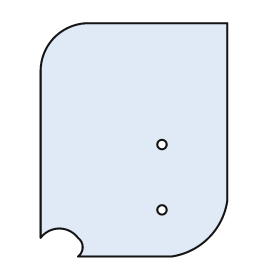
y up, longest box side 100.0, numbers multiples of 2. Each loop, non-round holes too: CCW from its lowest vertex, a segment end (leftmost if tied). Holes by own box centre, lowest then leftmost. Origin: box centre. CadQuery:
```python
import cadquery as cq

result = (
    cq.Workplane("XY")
    .moveTo(-24.0, -50.0)
    .lineTo(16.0, -50.0)
    .threePointArc((32.0, -42.0), (40.0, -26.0))
    .lineTo(40.0, 50.0)
    .lineTo(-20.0, 50.0)
    .threePointArc((-34.0, 44.0), (-40.0, 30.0))
    .lineTo(-40.0, -42.0)
    .threePointArc((-32.0, -38.0), (-24.0, -42.0))
    .threePointArc((-22.0, -46.0), (-24.0, -50.0))
    .close()
    .moveTo(12.0, -30.0)
    .circle(2.0)
    .moveTo(12.0, -2.0)
    .circle(2.0)
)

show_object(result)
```